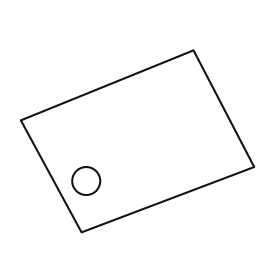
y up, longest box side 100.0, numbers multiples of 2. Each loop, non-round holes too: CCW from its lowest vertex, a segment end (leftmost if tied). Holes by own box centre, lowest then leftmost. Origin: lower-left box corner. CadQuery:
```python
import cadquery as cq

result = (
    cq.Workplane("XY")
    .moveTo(26.0, 0.0)
    .lineTo(100.0, 28.0)
    .lineTo(74.0, 78.0)
    .lineTo(0.0, 48.0)
    .close()
    .moveTo(28.0, 22.0)
    .circle(6.0)
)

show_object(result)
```